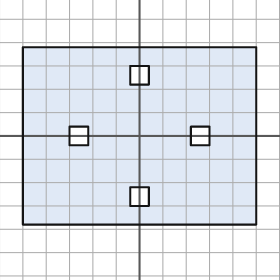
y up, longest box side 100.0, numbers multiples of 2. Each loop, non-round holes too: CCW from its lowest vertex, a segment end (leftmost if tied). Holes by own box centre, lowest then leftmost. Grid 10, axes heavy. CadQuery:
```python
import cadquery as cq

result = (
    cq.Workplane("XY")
    .moveTo(-50.0, -38.0)
    .lineTo(50.0, -38.0)
    .lineTo(50.0, 38.0)
    .lineTo(-50.0, 38.0)
    .close()
    .moveTo(-4.0, -30.0)
    .lineTo(4.0, -30.0)
    .lineTo(4.0, -22.0)
    .lineTo(-4.0, -22.0)
    .close()
    .moveTo(-30.0, -4.0)
    .lineTo(-22.0, -4.0)
    .lineTo(-22.0, 4.0)
    .lineTo(-30.0, 4.0)
    .close()
    .moveTo(22.0, -4.0)
    .lineTo(30.0, -4.0)
    .lineTo(30.0, 4.0)
    .lineTo(22.0, 4.0)
    .close()
    .moveTo(-4.0, 22.0)
    .lineTo(4.0, 22.0)
    .lineTo(4.0, 30.0)
    .lineTo(-4.0, 30.0)
    .close()
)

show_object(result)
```